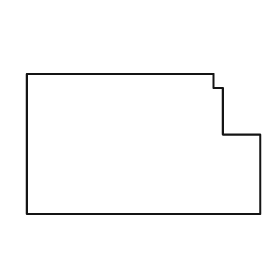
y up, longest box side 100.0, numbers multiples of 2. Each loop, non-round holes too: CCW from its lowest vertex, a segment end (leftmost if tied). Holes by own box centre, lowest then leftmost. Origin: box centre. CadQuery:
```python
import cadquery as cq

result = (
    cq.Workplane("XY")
    .moveTo(-50.0, -30.0)
    .lineTo(50.0, -30.0)
    .lineTo(50.0, 4.0)
    .lineTo(34.0, 4.0)
    .lineTo(34.0, 24.0)
    .lineTo(30.0, 24.0)
    .lineTo(30.0, 30.0)
    .lineTo(-50.0, 30.0)
    .close()
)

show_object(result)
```